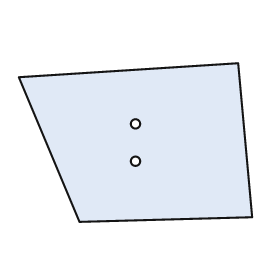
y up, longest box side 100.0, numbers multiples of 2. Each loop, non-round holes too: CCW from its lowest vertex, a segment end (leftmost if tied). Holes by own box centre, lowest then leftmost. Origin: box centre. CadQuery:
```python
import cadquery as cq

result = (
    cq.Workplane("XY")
    .moveTo(-24.0, -34.0)
    .lineTo(50.0, -32.0)
    .lineTo(44.0, 34.0)
    .lineTo(-50.0, 28.0)
    .close()
    .moveTo(0.0, -8.0)
    .circle(2.0)
    .moveTo(0.0, 8.0)
    .circle(2.0)
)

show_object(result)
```